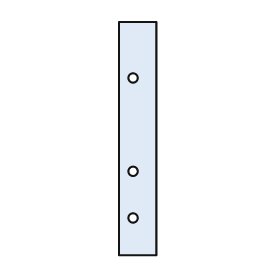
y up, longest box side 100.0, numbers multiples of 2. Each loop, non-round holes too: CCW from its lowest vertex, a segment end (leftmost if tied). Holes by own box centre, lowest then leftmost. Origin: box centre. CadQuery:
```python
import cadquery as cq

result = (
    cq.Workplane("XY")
    .moveTo(-8.0, -50.0)
    .lineTo(8.0, -50.0)
    .lineTo(8.0, 50.0)
    .lineTo(-8.0, 50.0)
    .close()
    .moveTo(-2.0, -34.0)
    .circle(2.0)
    .moveTo(-2.0, -14.0)
    .circle(2.0)
    .moveTo(-2.0, 26.0)
    .circle(2.0)
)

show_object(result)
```